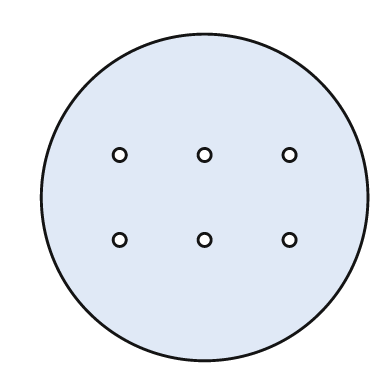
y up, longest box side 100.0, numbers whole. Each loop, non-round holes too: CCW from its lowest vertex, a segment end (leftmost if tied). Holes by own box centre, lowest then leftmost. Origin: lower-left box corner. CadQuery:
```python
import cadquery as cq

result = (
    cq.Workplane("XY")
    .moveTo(50.0, 50.0)
    .circle(50.0)
    .moveTo(24.0, 37.0)
    .circle(2.0)
    .moveTo(50.0, 37.0)
    .circle(2.0)
    .moveTo(76.0, 37.0)
    .circle(2.0)
    .moveTo(24.0, 63.0)
    .circle(2.0)
    .moveTo(50.0, 63.0)
    .circle(2.0)
    .moveTo(76.0, 63.0)
    .circle(2.0)
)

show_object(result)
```